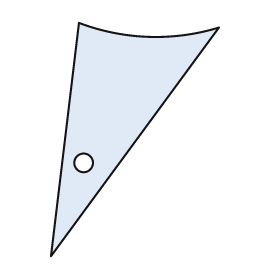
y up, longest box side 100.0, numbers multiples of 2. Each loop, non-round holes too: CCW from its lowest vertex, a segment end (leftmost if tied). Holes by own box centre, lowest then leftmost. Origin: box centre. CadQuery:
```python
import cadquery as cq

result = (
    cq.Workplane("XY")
    .moveTo(-36.0, -50.0)
    .lineTo(36.0, 48.0)
    .threePointArc((6.0, 44.0), (-24.0, 50.0))
    .close()
    .moveTo(-22.0, -10.0)
    .circle(4.0)
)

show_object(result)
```